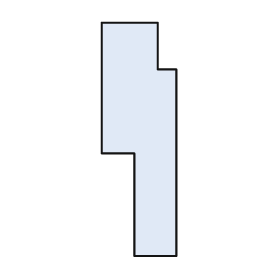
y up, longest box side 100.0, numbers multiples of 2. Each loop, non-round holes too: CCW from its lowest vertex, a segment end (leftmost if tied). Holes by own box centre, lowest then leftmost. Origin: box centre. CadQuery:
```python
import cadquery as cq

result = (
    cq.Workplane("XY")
    .moveTo(-2.0, -50.0)
    .lineTo(16.0, -50.0)
    .lineTo(16.0, 30.0)
    .lineTo(8.0, 30.0)
    .lineTo(8.0, 50.0)
    .lineTo(-16.0, 50.0)
    .lineTo(-16.0, -6.0)
    .lineTo(-2.0, -6.0)
    .close()
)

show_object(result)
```